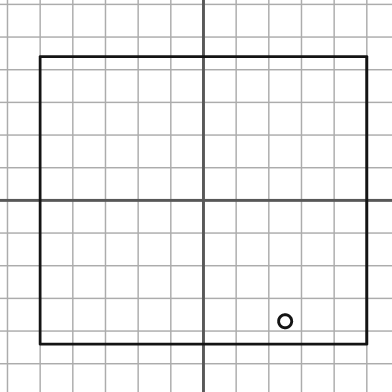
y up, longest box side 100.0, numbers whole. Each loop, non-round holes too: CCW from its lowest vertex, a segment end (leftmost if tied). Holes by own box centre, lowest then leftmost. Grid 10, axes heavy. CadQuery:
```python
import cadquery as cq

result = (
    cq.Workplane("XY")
    .moveTo(-50.0, -44.0)
    .lineTo(50.0, -44.0)
    .lineTo(50.0, 44.0)
    .lineTo(-50.0, 44.0)
    .close()
    .moveTo(25.0, -37.0)
    .circle(2.0)
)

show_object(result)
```